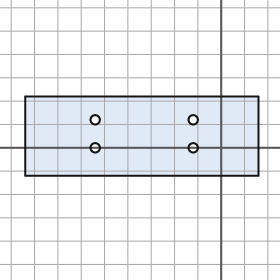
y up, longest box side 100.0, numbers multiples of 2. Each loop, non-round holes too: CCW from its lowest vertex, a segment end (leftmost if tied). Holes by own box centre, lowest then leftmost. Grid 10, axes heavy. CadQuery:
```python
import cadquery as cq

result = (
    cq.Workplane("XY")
    .moveTo(-84.0, -12.0)
    .lineTo(16.0, -12.0)
    .lineTo(16.0, 22.0)
    .lineTo(-84.0, 22.0)
    .close()
    .moveTo(-54.0, 0.0)
    .circle(2.0)
    .moveTo(-12.0, 0.0)
    .circle(2.0)
    .moveTo(-54.0, 12.0)
    .circle(2.0)
    .moveTo(-12.0, 12.0)
    .circle(2.0)
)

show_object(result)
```